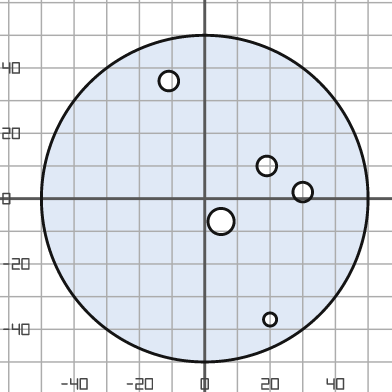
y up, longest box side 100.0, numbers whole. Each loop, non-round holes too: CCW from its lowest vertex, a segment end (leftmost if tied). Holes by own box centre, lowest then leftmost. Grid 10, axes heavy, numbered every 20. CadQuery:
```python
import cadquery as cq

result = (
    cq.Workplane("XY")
    .moveTo(0.0, 0.0)
    .circle(50.0)
    .moveTo(20.0, -37.0)
    .circle(2.0)
    .moveTo(5.0, -7.0)
    .circle(4.0)
    .moveTo(30.0, 2.0)
    .circle(3.0)
    .moveTo(19.0, 10.0)
    .circle(3.0)
    .moveTo(-11.0, 36.0)
    .circle(3.0)
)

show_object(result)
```